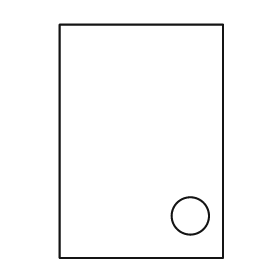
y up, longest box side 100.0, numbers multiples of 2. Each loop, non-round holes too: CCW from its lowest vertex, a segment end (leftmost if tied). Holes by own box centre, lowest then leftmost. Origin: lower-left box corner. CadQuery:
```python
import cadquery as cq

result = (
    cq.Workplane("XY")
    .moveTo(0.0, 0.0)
    .lineTo(70.0, 0.0)
    .lineTo(70.0, 100.0)
    .lineTo(0.0, 100.0)
    .close()
    .moveTo(56.0, 18.0)
    .circle(8.0)
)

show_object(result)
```